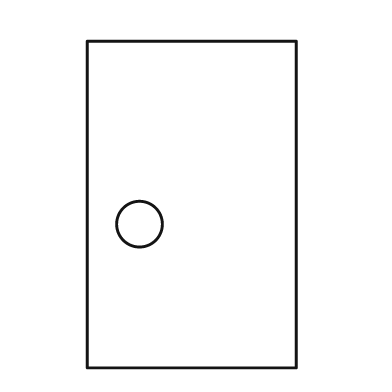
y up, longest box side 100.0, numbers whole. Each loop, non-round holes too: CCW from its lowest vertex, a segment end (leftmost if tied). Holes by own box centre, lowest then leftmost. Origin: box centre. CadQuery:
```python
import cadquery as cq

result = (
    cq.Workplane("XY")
    .moveTo(-32.0, -50.0)
    .lineTo(32.0, -50.0)
    .lineTo(32.0, 50.0)
    .lineTo(-32.0, 50.0)
    .close()
    .moveTo(-16.0, -6.0)
    .circle(7.0)
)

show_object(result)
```